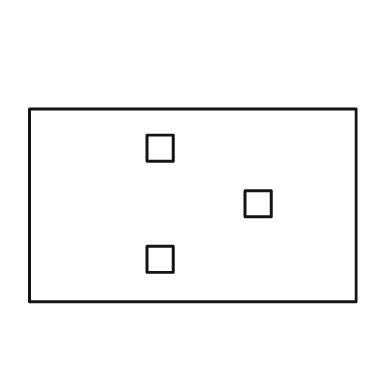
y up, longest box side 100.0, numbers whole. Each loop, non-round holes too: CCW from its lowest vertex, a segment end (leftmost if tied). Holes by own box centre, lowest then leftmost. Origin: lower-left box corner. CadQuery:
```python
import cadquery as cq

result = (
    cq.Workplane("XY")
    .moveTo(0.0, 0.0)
    .lineTo(100.0, 0.0)
    .lineTo(100.0, 59.0)
    .lineTo(0.0, 59.0)
    .close()
    .moveTo(36.0, 9.0)
    .lineTo(44.0, 9.0)
    .lineTo(44.0, 17.0)
    .lineTo(36.0, 17.0)
    .close()
    .moveTo(66.0, 26.0)
    .lineTo(74.0, 26.0)
    .lineTo(74.0, 34.0)
    .lineTo(66.0, 34.0)
    .close()
    .moveTo(36.0, 43.0)
    .lineTo(44.0, 43.0)
    .lineTo(44.0, 51.0)
    .lineTo(36.0, 51.0)
    .close()
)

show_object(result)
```